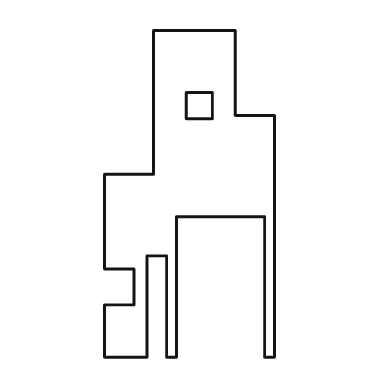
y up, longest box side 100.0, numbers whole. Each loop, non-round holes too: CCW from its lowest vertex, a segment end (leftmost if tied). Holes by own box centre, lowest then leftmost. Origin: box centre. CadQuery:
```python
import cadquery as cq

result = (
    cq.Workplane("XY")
    .moveTo(-26.0, -50.0)
    .lineTo(-13.0, -50.0)
    .lineTo(-13.0, -19.0)
    .lineTo(-7.0, -19.0)
    .lineTo(-7.0, -50.0)
    .lineTo(-4.0, -50.0)
    .lineTo(-4.0, -7.0)
    .lineTo(23.0, -7.0)
    .lineTo(23.0, -50.0)
    .lineTo(26.0, -50.0)
    .lineTo(26.0, 24.0)
    .lineTo(14.0, 24.0)
    .lineTo(14.0, 50.0)
    .lineTo(-11.0, 50.0)
    .lineTo(-11.0, 6.0)
    .lineTo(-26.0, 6.0)
    .lineTo(-26.0, -23.0)
    .lineTo(-17.0, -23.0)
    .lineTo(-17.0, -34.0)
    .lineTo(-26.0, -34.0)
    .close()
    .moveTo(-1.0, 23.0)
    .lineTo(7.0, 23.0)
    .lineTo(7.0, 31.0)
    .lineTo(-1.0, 31.0)
    .close()
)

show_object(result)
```